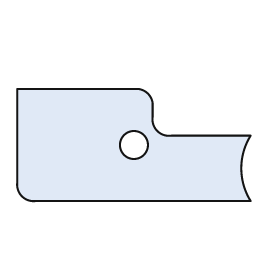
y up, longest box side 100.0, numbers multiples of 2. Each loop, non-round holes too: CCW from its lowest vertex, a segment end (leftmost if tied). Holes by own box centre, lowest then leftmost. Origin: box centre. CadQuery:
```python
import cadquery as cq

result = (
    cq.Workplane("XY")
    .moveTo(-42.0, -24.0)
    .lineTo(50.0, -24.0)
    .threePointArc((46.0, -10.0), (50.0, 4.0))
    .lineTo(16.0, 4.0)
    .threePointArc((10.0, 6.0), (8.0, 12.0))
    .lineTo(8.0, 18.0)
    .threePointArc((6.0, 22.0), (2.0, 24.0))
    .lineTo(-50.0, 24.0)
    .lineTo(-50.0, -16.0)
    .threePointArc((-48.0, -22.0), (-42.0, -24.0))
    .close()
    .moveTo(0.0, 0.0)
    .circle(6.0)
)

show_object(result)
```